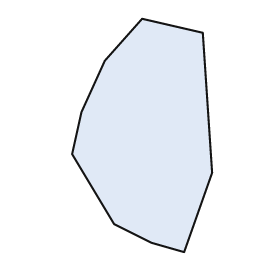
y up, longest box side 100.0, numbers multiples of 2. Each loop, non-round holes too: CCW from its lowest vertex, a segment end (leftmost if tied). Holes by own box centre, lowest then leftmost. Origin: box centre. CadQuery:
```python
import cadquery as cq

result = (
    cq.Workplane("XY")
    .moveTo(18.0, -50.0)
    .lineTo(30.0, -16.0)
    .lineTo(26.0, 44.0)
    .lineTo(0.0, 50.0)
    .lineTo(-16.0, 32.0)
    .lineTo(-26.0, 10.0)
    .lineTo(-30.0, -8.0)
    .lineTo(-12.0, -38.0)
    .lineTo(4.0, -46.0)
    .close()
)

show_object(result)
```